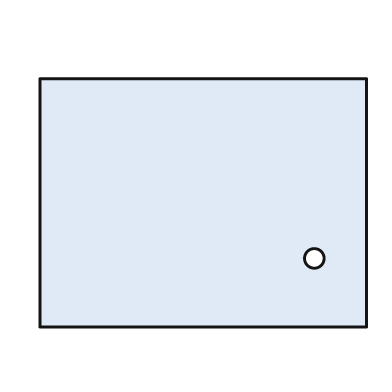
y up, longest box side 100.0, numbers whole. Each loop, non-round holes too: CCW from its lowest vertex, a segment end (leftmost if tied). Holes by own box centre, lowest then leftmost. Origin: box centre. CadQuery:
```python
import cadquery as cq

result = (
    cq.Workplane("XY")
    .moveTo(-50.0, -38.0)
    .lineTo(50.0, -38.0)
    .lineTo(50.0, 38.0)
    .lineTo(-50.0, 38.0)
    .close()
    .moveTo(34.0, -17.0)
    .circle(3.0)
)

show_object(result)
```